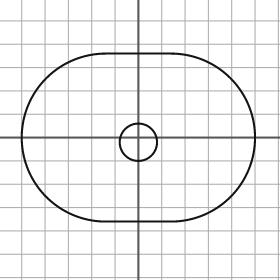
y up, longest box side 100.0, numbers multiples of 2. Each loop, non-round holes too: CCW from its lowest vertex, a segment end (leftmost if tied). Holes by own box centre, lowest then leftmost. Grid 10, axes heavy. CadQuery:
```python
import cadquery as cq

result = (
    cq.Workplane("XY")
    .moveTo(-14.0, -36.0)
    .lineTo(14.0, -36.0)
    .threePointArc((50.0, 0.0), (14.0, 36.0))
    .lineTo(-14.0, 36.0)
    .threePointArc((-50.0, 0.0), (-14.0, -36.0))
    .close()
    .moveTo(0.0, -2.0)
    .circle(8.0)
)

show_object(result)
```